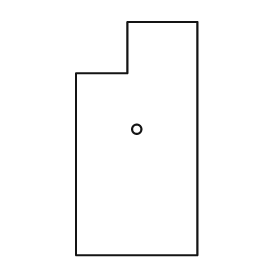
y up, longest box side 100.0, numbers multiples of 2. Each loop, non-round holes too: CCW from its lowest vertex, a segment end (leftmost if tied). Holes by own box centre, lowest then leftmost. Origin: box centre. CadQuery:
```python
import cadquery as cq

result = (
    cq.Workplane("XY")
    .moveTo(-26.0, -50.0)
    .lineTo(26.0, -50.0)
    .lineTo(26.0, 50.0)
    .lineTo(-4.0, 50.0)
    .lineTo(-4.0, 28.0)
    .lineTo(-26.0, 28.0)
    .close()
    .moveTo(0.0, 4.0)
    .circle(2.0)
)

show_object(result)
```